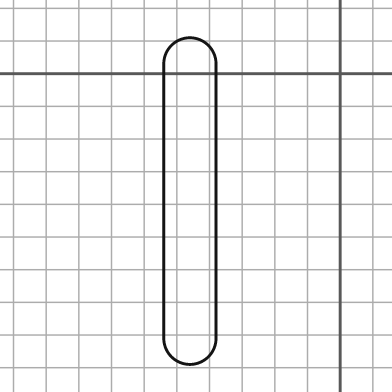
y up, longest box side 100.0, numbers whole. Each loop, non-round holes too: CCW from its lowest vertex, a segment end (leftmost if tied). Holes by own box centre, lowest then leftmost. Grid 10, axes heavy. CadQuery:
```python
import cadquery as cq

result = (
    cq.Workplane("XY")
    .moveTo(-54.0, -81.0)
    .threePointArc((-46.0, -89.0), (-38.0, -81.0))
    .lineTo(-38.0, 3.0)
    .threePointArc((-46.0, 11.0), (-54.0, 3.0))
    .close()
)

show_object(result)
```